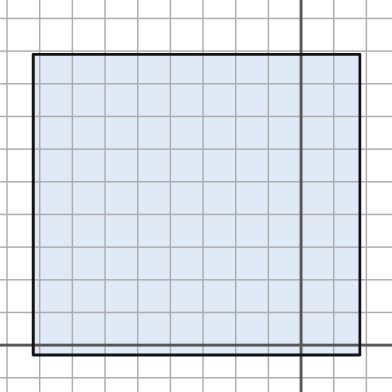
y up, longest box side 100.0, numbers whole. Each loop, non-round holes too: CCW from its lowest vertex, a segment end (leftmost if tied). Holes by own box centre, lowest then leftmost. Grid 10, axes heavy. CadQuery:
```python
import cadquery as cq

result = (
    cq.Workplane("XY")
    .moveTo(-82.0, -3.0)
    .lineTo(18.0, -3.0)
    .lineTo(18.0, 89.0)
    .lineTo(-82.0, 89.0)
    .close()
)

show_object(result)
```